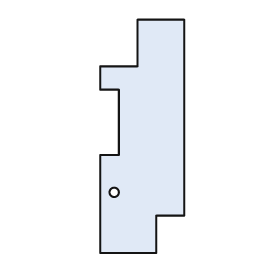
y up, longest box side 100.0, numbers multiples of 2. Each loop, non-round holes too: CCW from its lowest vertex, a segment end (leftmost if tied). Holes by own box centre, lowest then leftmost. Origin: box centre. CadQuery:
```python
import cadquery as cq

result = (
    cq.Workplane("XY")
    .moveTo(-18.0, -50.0)
    .lineTo(6.0, -50.0)
    .lineTo(6.0, -34.0)
    .lineTo(18.0, -34.0)
    .lineTo(18.0, 50.0)
    .lineTo(-2.0, 50.0)
    .lineTo(-2.0, 30.0)
    .lineTo(-18.0, 30.0)
    .lineTo(-18.0, 20.0)
    .lineTo(-10.0, 20.0)
    .lineTo(-10.0, -8.0)
    .lineTo(-18.0, -8.0)
    .close()
    .moveTo(-12.0, -24.0)
    .circle(2.0)
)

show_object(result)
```